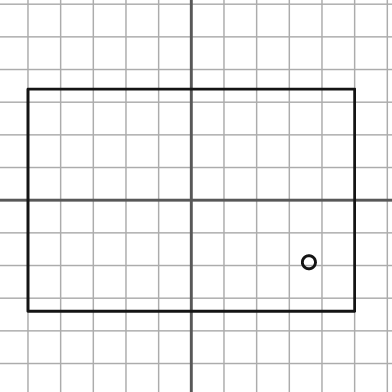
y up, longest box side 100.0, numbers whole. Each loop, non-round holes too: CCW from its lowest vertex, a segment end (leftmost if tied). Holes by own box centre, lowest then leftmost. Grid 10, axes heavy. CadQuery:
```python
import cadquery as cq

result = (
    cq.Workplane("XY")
    .moveTo(-50.0, -34.0)
    .lineTo(50.0, -34.0)
    .lineTo(50.0, 34.0)
    .lineTo(-50.0, 34.0)
    .close()
    .moveTo(36.0, -19.0)
    .circle(2.0)
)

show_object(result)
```